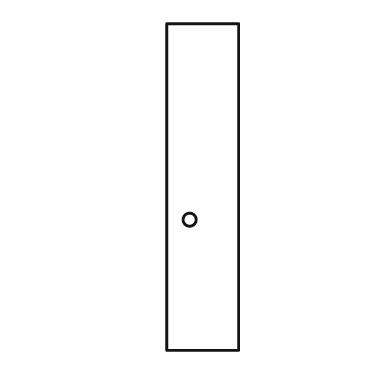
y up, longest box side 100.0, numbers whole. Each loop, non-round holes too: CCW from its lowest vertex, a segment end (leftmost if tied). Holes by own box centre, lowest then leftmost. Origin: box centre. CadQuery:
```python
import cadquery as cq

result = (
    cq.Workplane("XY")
    .moveTo(-11.0, -50.0)
    .lineTo(11.0, -50.0)
    .lineTo(11.0, 50.0)
    .lineTo(-11.0, 50.0)
    .close()
    .moveTo(-4.0, -10.0)
    .circle(2.0)
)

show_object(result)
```